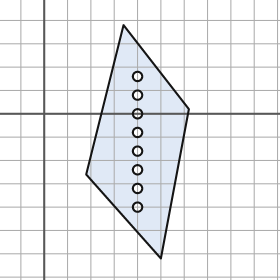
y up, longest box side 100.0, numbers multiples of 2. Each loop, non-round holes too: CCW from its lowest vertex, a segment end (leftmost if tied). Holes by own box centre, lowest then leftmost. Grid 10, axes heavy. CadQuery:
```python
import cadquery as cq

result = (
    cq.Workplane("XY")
    .moveTo(50.0, -62.0)
    .lineTo(62.0, 2.0)
    .lineTo(34.0, 38.0)
    .lineTo(18.0, -26.0)
    .close()
    .moveTo(40.0, -40.0)
    .circle(2.0)
    .moveTo(40.0, -32.0)
    .circle(2.0)
    .moveTo(40.0, -24.0)
    .circle(2.0)
    .moveTo(40.0, -16.0)
    .circle(2.0)
    .moveTo(40.0, -8.0)
    .circle(2.0)
    .moveTo(40.0, 0.0)
    .circle(2.0)
    .moveTo(40.0, 8.0)
    .circle(2.0)
    .moveTo(40.0, 16.0)
    .circle(2.0)
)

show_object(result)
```